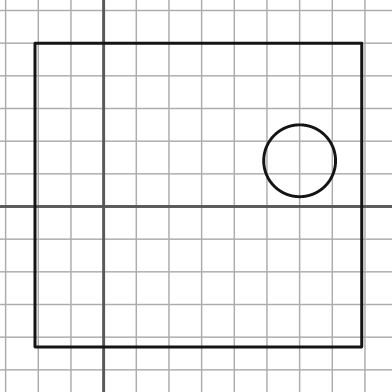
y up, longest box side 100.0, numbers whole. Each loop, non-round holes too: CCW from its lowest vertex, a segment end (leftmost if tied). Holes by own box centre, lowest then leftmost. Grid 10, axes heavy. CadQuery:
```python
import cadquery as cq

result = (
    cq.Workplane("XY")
    .moveTo(-21.0, -43.0)
    .lineTo(79.0, -43.0)
    .lineTo(79.0, 50.0)
    .lineTo(-21.0, 50.0)
    .close()
    .moveTo(60.0, 14.0)
    .circle(11.0)
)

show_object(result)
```